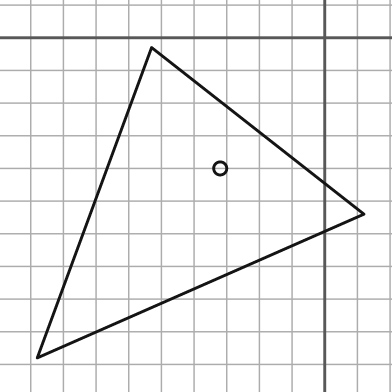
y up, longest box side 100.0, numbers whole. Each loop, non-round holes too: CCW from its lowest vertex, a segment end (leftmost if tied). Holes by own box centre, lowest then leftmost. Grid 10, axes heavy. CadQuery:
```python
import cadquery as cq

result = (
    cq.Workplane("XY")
    .moveTo(-88.0, -98.0)
    .lineTo(12.0, -54.0)
    .lineTo(-53.0, -3.0)
    .close()
    .moveTo(-32.0, -40.0)
    .circle(2.0)
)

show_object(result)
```